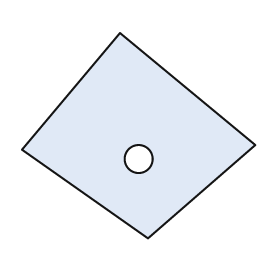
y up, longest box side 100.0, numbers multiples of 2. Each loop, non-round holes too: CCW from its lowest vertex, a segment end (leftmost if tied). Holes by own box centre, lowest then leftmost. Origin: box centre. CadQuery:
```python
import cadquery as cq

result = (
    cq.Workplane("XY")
    .moveTo(4.0, -44.0)
    .lineTo(50.0, -4.0)
    .lineTo(-8.0, 44.0)
    .lineTo(-50.0, -6.0)
    .close()
    .moveTo(0.0, -10.0)
    .circle(6.0)
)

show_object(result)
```